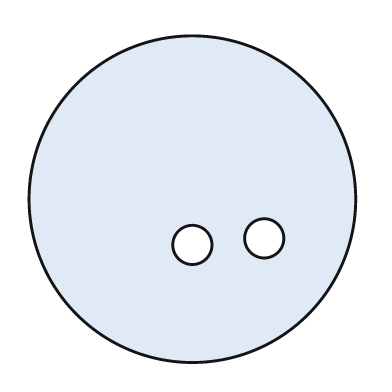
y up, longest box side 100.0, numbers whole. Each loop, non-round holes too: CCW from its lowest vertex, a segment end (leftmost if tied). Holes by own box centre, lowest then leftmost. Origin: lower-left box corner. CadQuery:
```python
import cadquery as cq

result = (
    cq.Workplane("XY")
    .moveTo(50.0, 50.0)
    .circle(50.0)
    .moveTo(50.0, 36.0)
    .circle(6.0)
    .moveTo(72.0, 38.0)
    .circle(6.0)
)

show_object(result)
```